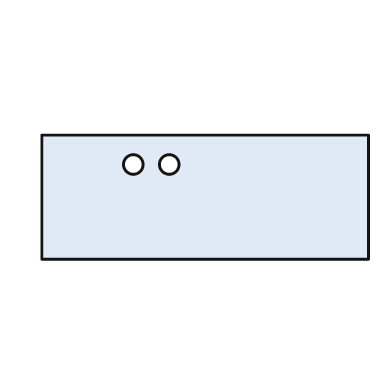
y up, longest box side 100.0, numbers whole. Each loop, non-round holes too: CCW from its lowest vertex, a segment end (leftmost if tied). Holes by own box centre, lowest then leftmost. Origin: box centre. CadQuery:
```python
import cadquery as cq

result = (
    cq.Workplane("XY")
    .moveTo(-50.0, -19.0)
    .lineTo(50.0, -19.0)
    .lineTo(50.0, 19.0)
    .lineTo(-50.0, 19.0)
    .close()
    .moveTo(-22.0, 10.0)
    .circle(3.0)
    .moveTo(-11.0, 10.0)
    .circle(3.0)
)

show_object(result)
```